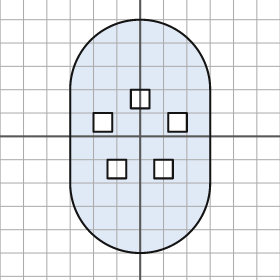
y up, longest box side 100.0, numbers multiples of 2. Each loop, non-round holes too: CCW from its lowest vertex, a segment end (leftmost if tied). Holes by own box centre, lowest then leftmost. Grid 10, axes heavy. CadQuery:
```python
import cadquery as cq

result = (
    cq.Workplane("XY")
    .moveTo(-30.0, -20.0)
    .threePointArc((0.0, -50.0), (30.0, -20.0))
    .lineTo(30.0, 20.0)
    .threePointArc((0.0, 50.0), (-30.0, 20.0))
    .close()
    .moveTo(-14.0, -18.0)
    .lineTo(-6.0, -18.0)
    .lineTo(-6.0, -10.0)
    .lineTo(-14.0, -10.0)
    .close()
    .moveTo(6.0, -18.0)
    .lineTo(14.0, -18.0)
    .lineTo(14.0, -10.0)
    .lineTo(6.0, -10.0)
    .close()
    .moveTo(-20.0, 2.0)
    .lineTo(-12.0, 2.0)
    .lineTo(-12.0, 10.0)
    .lineTo(-20.0, 10.0)
    .close()
    .moveTo(12.0, 2.0)
    .lineTo(20.0, 2.0)
    .lineTo(20.0, 10.0)
    .lineTo(12.0, 10.0)
    .close()
    .moveTo(-4.0, 12.0)
    .lineTo(4.0, 12.0)
    .lineTo(4.0, 20.0)
    .lineTo(-4.0, 20.0)
    .close()
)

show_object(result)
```